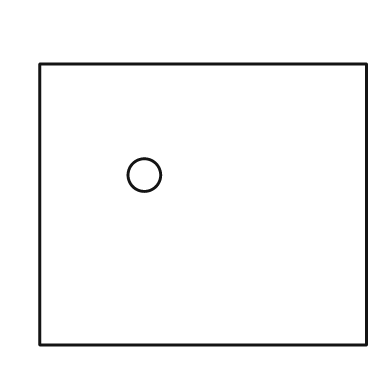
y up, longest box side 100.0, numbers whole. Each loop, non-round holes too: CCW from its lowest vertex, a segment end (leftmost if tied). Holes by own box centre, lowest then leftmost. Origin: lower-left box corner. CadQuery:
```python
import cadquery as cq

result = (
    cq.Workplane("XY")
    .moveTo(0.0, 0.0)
    .lineTo(100.0, 0.0)
    .lineTo(100.0, 86.0)
    .lineTo(0.0, 86.0)
    .close()
    .moveTo(32.0, 52.0)
    .circle(5.0)
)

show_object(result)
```